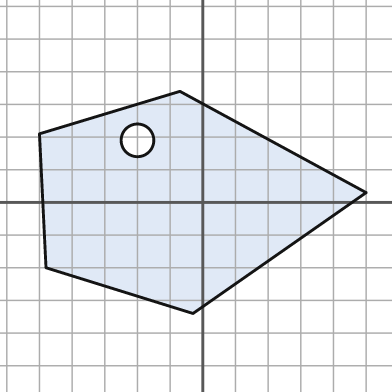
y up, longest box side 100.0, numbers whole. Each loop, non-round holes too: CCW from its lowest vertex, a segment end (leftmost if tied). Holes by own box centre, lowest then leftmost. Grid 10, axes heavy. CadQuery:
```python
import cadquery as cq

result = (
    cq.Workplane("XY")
    .moveTo(-3.0, -34.0)
    .lineTo(50.0, 3.0)
    .lineTo(-7.0, 34.0)
    .lineTo(-50.0, 21.0)
    .lineTo(-48.0, -20.0)
    .close()
    .moveTo(-20.0, 19.0)
    .circle(5.0)
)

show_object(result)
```